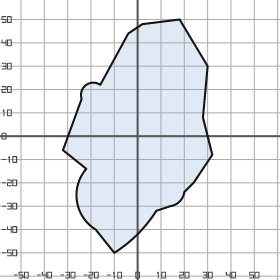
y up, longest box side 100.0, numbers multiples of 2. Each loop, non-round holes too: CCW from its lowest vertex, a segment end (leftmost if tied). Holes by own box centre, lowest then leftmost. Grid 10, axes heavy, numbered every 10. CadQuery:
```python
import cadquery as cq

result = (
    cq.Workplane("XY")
    .moveTo(-10.0, -50.0)
    .threePointArc((0.0, -42.0), (8.0, -32.0))
    .lineTo(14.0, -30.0)
    .threePointArc((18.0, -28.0), (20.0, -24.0))
    .lineTo(24.0, -20.0)
    .lineTo(32.0, -8.0)
    .lineTo(28.0, 8.0)
    .lineTo(30.0, 30.0)
    .lineTo(18.0, 50.0)
    .lineTo(2.0, 48.0)
    .lineTo(-4.0, 44.0)
    .lineTo(-16.0, 22.0)
    .threePointArc((-22.0, 22.0), (-24.0, 16.0))
    .lineTo(-32.0, -6.0)
    .lineTo(-22.0, -14.0)
    .threePointArc((-26.0, -28.0), (-18.0, -40.0))
    .close()
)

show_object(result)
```